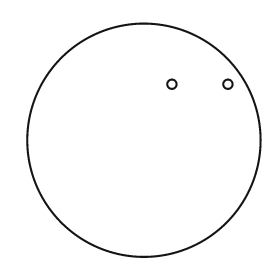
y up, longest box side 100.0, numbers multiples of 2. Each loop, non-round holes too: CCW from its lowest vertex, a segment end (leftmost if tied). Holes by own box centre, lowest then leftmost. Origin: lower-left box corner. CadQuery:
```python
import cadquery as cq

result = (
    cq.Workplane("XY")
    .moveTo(50.0, 50.0)
    .circle(50.0)
    .moveTo(62.0, 74.0)
    .circle(2.0)
    .moveTo(86.0, 74.0)
    .circle(2.0)
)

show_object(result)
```